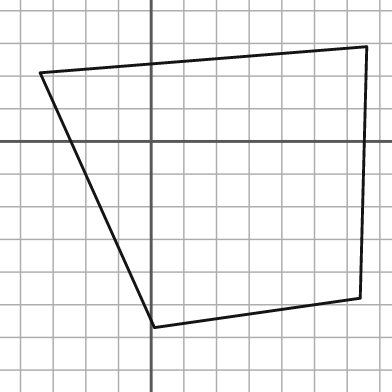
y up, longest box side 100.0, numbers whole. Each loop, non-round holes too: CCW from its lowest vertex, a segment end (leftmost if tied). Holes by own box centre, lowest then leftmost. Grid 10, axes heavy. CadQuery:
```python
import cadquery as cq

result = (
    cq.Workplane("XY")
    .moveTo(1.0, -57.0)
    .lineTo(64.0, -48.0)
    .lineTo(66.0, 29.0)
    .lineTo(-34.0, 21.0)
    .close()
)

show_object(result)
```